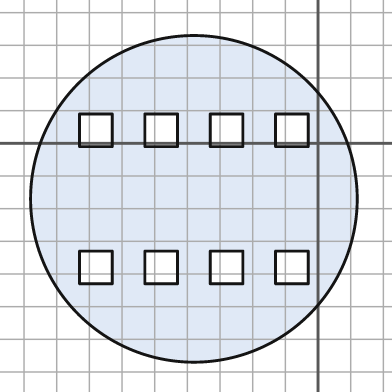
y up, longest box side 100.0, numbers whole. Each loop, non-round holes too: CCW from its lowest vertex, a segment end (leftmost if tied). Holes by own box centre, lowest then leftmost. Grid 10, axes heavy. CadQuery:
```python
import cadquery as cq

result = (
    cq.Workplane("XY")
    .moveTo(-38.0, -17.0)
    .circle(50.0)
    .moveTo(-73.0, -43.0)
    .lineTo(-63.0, -43.0)
    .lineTo(-63.0, -33.0)
    .lineTo(-73.0, -33.0)
    .close()
    .moveTo(-53.0, -43.0)
    .lineTo(-43.0, -43.0)
    .lineTo(-43.0, -33.0)
    .lineTo(-53.0, -33.0)
    .close()
    .moveTo(-33.0, -43.0)
    .lineTo(-23.0, -43.0)
    .lineTo(-23.0, -33.0)
    .lineTo(-33.0, -33.0)
    .close()
    .moveTo(-13.0, -43.0)
    .lineTo(-3.0, -43.0)
    .lineTo(-3.0, -33.0)
    .lineTo(-13.0, -33.0)
    .close()
    .moveTo(-73.0, -1.0)
    .lineTo(-63.0, -1.0)
    .lineTo(-63.0, 9.0)
    .lineTo(-73.0, 9.0)
    .close()
    .moveTo(-53.0, -1.0)
    .lineTo(-43.0, -1.0)
    .lineTo(-43.0, 9.0)
    .lineTo(-53.0, 9.0)
    .close()
    .moveTo(-33.0, -1.0)
    .lineTo(-23.0, -1.0)
    .lineTo(-23.0, 9.0)
    .lineTo(-33.0, 9.0)
    .close()
    .moveTo(-13.0, -1.0)
    .lineTo(-3.0, -1.0)
    .lineTo(-3.0, 9.0)
    .lineTo(-13.0, 9.0)
    .close()
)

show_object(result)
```